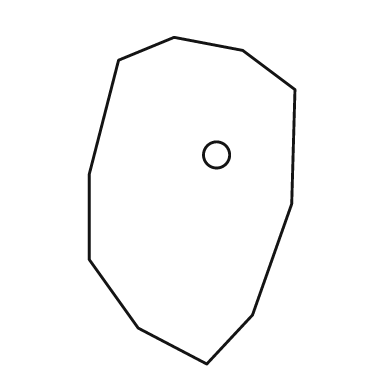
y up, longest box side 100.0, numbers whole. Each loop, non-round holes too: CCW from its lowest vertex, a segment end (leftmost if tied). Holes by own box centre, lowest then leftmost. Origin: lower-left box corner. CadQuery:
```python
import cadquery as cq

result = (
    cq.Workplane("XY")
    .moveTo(36.0, 0.0)
    .lineTo(50.0, 15.0)
    .lineTo(62.0, 49.0)
    .lineTo(63.0, 84.0)
    .lineTo(47.0, 96.0)
    .lineTo(26.0, 100.0)
    .lineTo(9.0, 93.0)
    .lineTo(0.0, 58.0)
    .lineTo(0.0, 32.0)
    .lineTo(15.0, 11.0)
    .close()
    .moveTo(39.0, 64.0)
    .circle(4.0)
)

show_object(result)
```